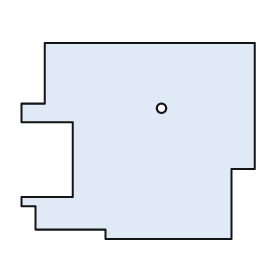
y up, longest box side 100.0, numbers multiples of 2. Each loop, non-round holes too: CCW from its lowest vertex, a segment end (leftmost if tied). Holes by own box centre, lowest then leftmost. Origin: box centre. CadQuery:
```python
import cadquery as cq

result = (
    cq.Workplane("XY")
    .moveTo(-14.0, -42.0)
    .lineTo(40.0, -42.0)
    .lineTo(40.0, -12.0)
    .lineTo(50.0, -12.0)
    .lineTo(50.0, 42.0)
    .lineTo(-40.0, 42.0)
    .lineTo(-40.0, 16.0)
    .lineTo(-50.0, 16.0)
    .lineTo(-50.0, 8.0)
    .lineTo(-28.0, 8.0)
    .lineTo(-28.0, -24.0)
    .lineTo(-50.0, -24.0)
    .lineTo(-50.0, -28.0)
    .lineTo(-44.0, -28.0)
    .lineTo(-44.0, -38.0)
    .lineTo(-14.0, -38.0)
    .close()
    .moveTo(10.0, 14.0)
    .circle(2.0)
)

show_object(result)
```